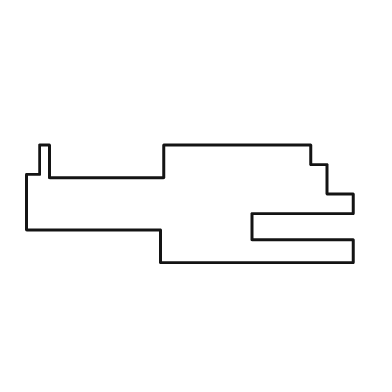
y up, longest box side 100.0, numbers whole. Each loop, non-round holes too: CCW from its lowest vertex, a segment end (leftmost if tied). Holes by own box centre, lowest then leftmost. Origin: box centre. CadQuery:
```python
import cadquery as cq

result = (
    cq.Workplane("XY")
    .moveTo(-9.0, -18.0)
    .lineTo(50.0, -18.0)
    .lineTo(50.0, -11.0)
    .lineTo(19.0, -11.0)
    .lineTo(19.0, -3.0)
    .lineTo(50.0, -3.0)
    .lineTo(50.0, 3.0)
    .lineTo(42.0, 3.0)
    .lineTo(42.0, 12.0)
    .lineTo(37.0, 12.0)
    .lineTo(37.0, 18.0)
    .lineTo(-8.0, 18.0)
    .lineTo(-8.0, 8.0)
    .lineTo(-43.0, 8.0)
    .lineTo(-43.0, 18.0)
    .lineTo(-46.0, 18.0)
    .lineTo(-46.0, 9.0)
    .lineTo(-50.0, 9.0)
    .lineTo(-50.0, -8.0)
    .lineTo(-9.0, -8.0)
    .close()
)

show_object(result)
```